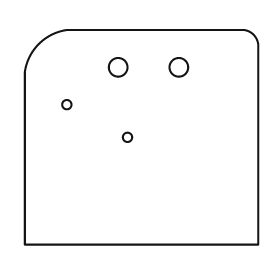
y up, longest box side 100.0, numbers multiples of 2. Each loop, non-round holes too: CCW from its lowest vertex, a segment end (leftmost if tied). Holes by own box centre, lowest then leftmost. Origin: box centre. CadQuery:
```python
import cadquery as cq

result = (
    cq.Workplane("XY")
    .moveTo(-50.0, -46.0)
    .lineTo(50.0, -46.0)
    .lineTo(50.0, 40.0)
    .threePointArc((48.0, 44.0), (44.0, 46.0))
    .lineTo(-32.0, 46.0)
    .threePointArc((-44.0, 40.0), (-50.0, 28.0))
    .close()
    .moveTo(-6.0, 0.0)
    .circle(2.0)
    .moveTo(-32.0, 14.0)
    .circle(2.0)
    .moveTo(-10.0, 30.0)
    .circle(4.0)
    .moveTo(16.0, 30.0)
    .circle(4.0)
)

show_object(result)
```